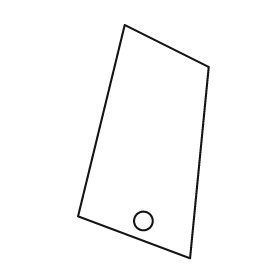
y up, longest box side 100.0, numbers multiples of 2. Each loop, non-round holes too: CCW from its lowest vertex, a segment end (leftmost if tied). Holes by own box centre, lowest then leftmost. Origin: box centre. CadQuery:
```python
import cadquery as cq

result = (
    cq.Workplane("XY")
    .moveTo(20.0, -50.0)
    .lineTo(28.0, 32.0)
    .lineTo(-8.0, 50.0)
    .lineTo(-28.0, -32.0)
    .close()
    .moveTo(0.0, -34.0)
    .circle(4.0)
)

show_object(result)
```